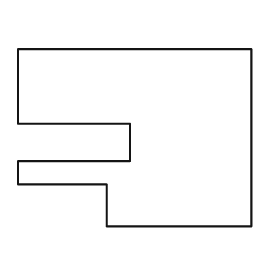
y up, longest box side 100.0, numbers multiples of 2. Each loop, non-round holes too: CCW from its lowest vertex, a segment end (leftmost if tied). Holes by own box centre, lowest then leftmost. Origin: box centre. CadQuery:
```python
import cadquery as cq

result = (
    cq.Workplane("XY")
    .moveTo(-12.0, -38.0)
    .lineTo(50.0, -38.0)
    .lineTo(50.0, 38.0)
    .lineTo(-50.0, 38.0)
    .lineTo(-50.0, 6.0)
    .lineTo(-2.0, 6.0)
    .lineTo(-2.0, -10.0)
    .lineTo(-50.0, -10.0)
    .lineTo(-50.0, -20.0)
    .lineTo(-12.0, -20.0)
    .close()
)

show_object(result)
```